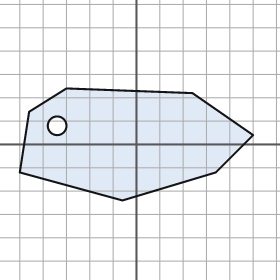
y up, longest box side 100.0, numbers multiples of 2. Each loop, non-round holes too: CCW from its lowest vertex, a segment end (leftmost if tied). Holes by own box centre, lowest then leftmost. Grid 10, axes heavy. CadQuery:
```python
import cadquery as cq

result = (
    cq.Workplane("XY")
    .moveTo(-6.0, -24.0)
    .lineTo(34.0, -12.0)
    .lineTo(50.0, 4.0)
    .lineTo(24.0, 22.0)
    .lineTo(-30.0, 24.0)
    .lineTo(-46.0, 14.0)
    .lineTo(-50.0, -12.0)
    .close()
    .moveTo(-34.0, 8.0)
    .circle(4.0)
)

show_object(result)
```